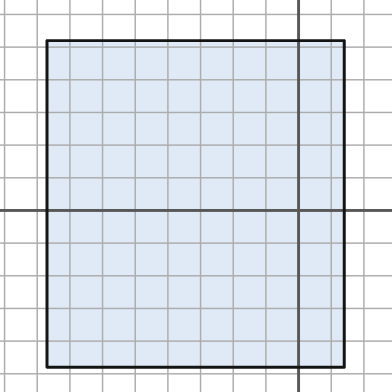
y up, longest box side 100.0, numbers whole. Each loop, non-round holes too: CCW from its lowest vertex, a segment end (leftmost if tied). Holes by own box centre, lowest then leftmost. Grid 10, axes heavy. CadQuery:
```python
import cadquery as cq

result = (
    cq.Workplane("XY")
    .moveTo(-77.0, -48.0)
    .lineTo(14.0, -48.0)
    .lineTo(14.0, 52.0)
    .lineTo(-77.0, 52.0)
    .close()
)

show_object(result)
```